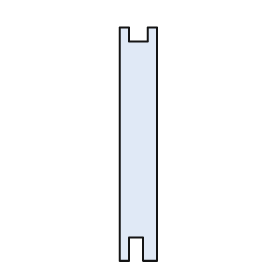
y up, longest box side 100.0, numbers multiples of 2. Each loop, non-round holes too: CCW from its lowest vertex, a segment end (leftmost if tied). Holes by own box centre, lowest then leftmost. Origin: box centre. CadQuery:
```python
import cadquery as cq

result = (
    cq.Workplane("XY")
    .moveTo(-8.0, -50.0)
    .lineTo(-4.0, -50.0)
    .lineTo(-4.0, -40.0)
    .lineTo(2.0, -40.0)
    .lineTo(2.0, -50.0)
    .lineTo(8.0, -50.0)
    .lineTo(8.0, 50.0)
    .lineTo(4.0, 50.0)
    .lineTo(4.0, 44.0)
    .lineTo(-4.0, 44.0)
    .lineTo(-4.0, 50.0)
    .lineTo(-8.0, 50.0)
    .close()
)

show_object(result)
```